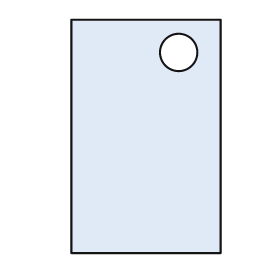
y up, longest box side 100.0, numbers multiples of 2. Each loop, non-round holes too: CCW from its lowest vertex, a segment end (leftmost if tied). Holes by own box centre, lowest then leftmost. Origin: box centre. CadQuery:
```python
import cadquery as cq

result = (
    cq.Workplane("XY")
    .moveTo(-32.0, -50.0)
    .lineTo(32.0, -50.0)
    .lineTo(32.0, 50.0)
    .lineTo(-32.0, 50.0)
    .close()
    .moveTo(14.0, 36.0)
    .circle(8.0)
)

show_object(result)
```